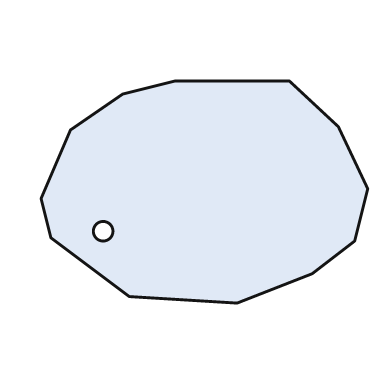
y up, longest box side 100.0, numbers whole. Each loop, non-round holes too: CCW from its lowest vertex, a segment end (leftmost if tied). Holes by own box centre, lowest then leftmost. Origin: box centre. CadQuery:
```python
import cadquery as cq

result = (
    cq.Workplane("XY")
    .moveTo(10.0, -34.0)
    .lineTo(33.0, -25.0)
    .lineTo(46.0, -15.0)
    .lineTo(50.0, 1.0)
    .lineTo(41.0, 20.0)
    .lineTo(26.0, 34.0)
    .lineTo(-9.0, 34.0)
    .lineTo(-25.0, 30.0)
    .lineTo(-41.0, 19.0)
    .lineTo(-50.0, -2.0)
    .lineTo(-47.0, -14.0)
    .lineTo(-23.0, -32.0)
    .close()
    .moveTo(-31.0, -12.0)
    .circle(3.0)
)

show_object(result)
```